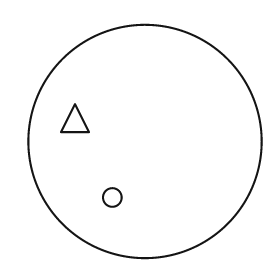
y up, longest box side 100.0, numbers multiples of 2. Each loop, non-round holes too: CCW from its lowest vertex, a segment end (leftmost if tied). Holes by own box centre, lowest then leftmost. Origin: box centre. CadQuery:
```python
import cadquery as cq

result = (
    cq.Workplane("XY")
    .moveTo(0.0, 0.0)
    .circle(50.0)
    .moveTo(-14.0, -24.0)
    .circle(4.0)
    .moveTo(-36.0, 4.0)
    .lineTo(-24.0, 4.0)
    .lineTo(-30.0, 16.0)
    .close()
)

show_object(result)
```